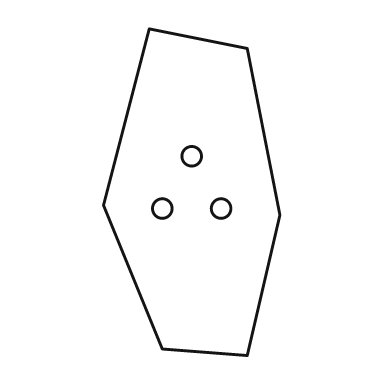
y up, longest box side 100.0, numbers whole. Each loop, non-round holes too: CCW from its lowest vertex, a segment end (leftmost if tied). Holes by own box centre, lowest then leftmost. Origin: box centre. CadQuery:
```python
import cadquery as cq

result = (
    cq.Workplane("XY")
    .moveTo(17.0, -50.0)
    .lineTo(27.0, -7.0)
    .lineTo(17.0, 44.0)
    .lineTo(-13.0, 50.0)
    .lineTo(-27.0, -4.0)
    .lineTo(-9.0, -48.0)
    .close()
    .moveTo(-9.0, -5.0)
    .circle(3.0)
    .moveTo(9.0, -5.0)
    .circle(3.0)
    .moveTo(0.0, 11.0)
    .circle(3.0)
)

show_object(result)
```